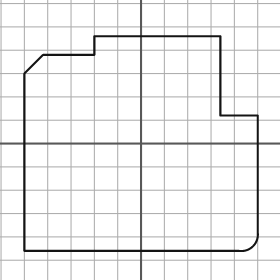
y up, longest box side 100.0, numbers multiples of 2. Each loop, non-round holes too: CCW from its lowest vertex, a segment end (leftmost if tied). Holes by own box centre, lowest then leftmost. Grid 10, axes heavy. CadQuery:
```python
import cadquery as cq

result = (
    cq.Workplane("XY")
    .moveTo(-50.0, -46.0)
    .lineTo(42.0, -46.0)
    .threePointArc((48.0, -44.0), (50.0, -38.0))
    .lineTo(50.0, 12.0)
    .lineTo(34.0, 12.0)
    .lineTo(34.0, 46.0)
    .lineTo(-20.0, 46.0)
    .lineTo(-20.0, 38.0)
    .lineTo(-42.0, 38.0)
    .lineTo(-50.0, 30.0)
    .close()
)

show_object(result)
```